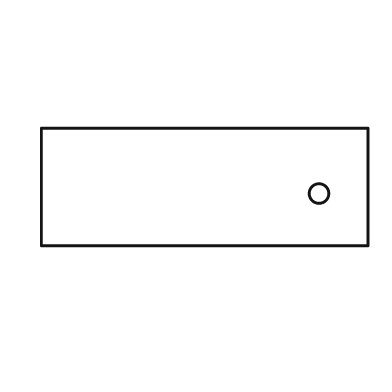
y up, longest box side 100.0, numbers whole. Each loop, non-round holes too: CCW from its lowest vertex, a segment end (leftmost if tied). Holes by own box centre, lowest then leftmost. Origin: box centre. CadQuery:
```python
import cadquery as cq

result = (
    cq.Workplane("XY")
    .moveTo(-50.0, -18.0)
    .lineTo(50.0, -18.0)
    .lineTo(50.0, 18.0)
    .lineTo(-50.0, 18.0)
    .close()
    .moveTo(35.0, -2.0)
    .circle(3.0)
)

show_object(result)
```